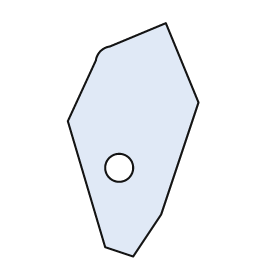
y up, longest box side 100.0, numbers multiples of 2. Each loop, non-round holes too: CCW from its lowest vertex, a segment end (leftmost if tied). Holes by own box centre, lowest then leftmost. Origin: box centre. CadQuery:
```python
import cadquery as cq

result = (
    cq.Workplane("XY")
    .moveTo(0.0, -50.0)
    .lineTo(12.0, -32.0)
    .lineTo(28.0, 16.0)
    .lineTo(14.0, 50.0)
    .lineTo(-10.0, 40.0)
    .threePointArc((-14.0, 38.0), (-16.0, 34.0))
    .lineTo(-28.0, 8.0)
    .lineTo(-12.0, -46.0)
    .close()
    .moveTo(-6.0, -12.0)
    .circle(6.0)
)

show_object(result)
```